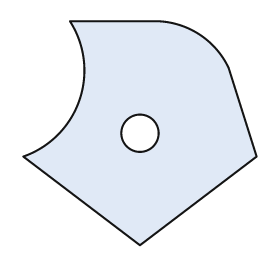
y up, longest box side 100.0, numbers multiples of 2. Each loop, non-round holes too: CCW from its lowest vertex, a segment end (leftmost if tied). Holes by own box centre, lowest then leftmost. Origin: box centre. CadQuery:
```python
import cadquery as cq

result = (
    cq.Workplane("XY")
    .moveTo(0.0, -48.0)
    .lineTo(50.0, -10.0)
    .lineTo(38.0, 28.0)
    .threePointArc((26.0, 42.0), (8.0, 48.0))
    .lineTo(-30.0, 48.0)
    .threePointArc((-26.0, 14.0), (-50.0, -10.0))
    .close()
    .moveTo(0.0, 0.0)
    .circle(8.0)
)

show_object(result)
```